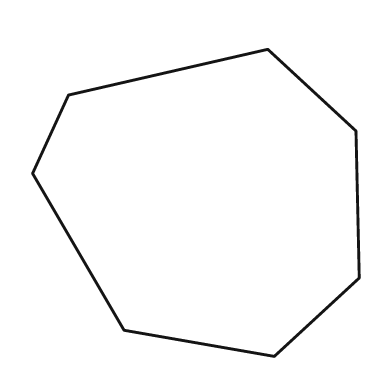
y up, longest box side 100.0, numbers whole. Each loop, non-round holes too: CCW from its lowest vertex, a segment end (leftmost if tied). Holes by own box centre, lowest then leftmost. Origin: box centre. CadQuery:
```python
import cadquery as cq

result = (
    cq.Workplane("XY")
    .moveTo(24.0, -47.0)
    .lineTo(50.0, -23.0)
    .lineTo(49.0, 22.0)
    .lineTo(22.0, 47.0)
    .lineTo(-39.0, 33.0)
    .lineTo(-50.0, 9.0)
    .lineTo(-22.0, -39.0)
    .close()
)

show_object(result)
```